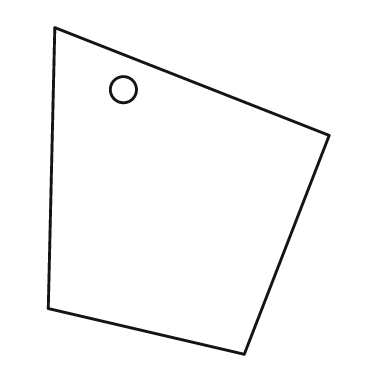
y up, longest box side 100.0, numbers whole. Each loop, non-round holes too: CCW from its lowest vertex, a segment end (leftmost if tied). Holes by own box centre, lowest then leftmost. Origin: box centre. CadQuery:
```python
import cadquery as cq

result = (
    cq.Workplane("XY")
    .moveTo(17.0, -50.0)
    .lineTo(43.0, 17.0)
    .lineTo(-41.0, 50.0)
    .lineTo(-43.0, -36.0)
    .close()
    .moveTo(-20.0, 31.0)
    .circle(4.0)
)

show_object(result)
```